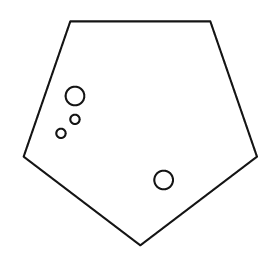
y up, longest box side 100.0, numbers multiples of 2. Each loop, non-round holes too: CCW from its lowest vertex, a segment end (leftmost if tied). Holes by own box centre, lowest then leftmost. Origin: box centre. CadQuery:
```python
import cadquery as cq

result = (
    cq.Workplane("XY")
    .moveTo(0.0, -48.0)
    .lineTo(50.0, -10.0)
    .lineTo(30.0, 48.0)
    .lineTo(-30.0, 48.0)
    .lineTo(-50.0, -10.0)
    .close()
    .moveTo(10.0, -20.0)
    .circle(4.0)
    .moveTo(-34.0, 0.0)
    .circle(2.0)
    .moveTo(-28.0, 6.0)
    .circle(2.0)
    .moveTo(-28.0, 16.0)
    .circle(4.0)
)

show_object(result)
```